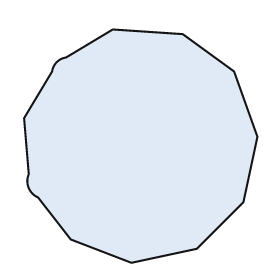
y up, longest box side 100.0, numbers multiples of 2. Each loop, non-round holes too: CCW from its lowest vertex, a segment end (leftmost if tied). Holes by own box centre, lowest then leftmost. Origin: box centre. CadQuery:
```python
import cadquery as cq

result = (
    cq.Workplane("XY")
    .moveTo(-4.0, -50.0)
    .lineTo(24.0, -44.0)
    .lineTo(44.0, -24.0)
    .lineTo(50.0, 4.0)
    .lineTo(40.0, 32.0)
    .lineTo(18.0, 48.0)
    .lineTo(-12.0, 50.0)
    .lineTo(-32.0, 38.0)
    .threePointArc((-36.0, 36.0), (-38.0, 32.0))
    .lineTo(-50.0, 12.0)
    .lineTo(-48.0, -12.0)
    .threePointArc((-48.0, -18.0), (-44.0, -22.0))
    .lineTo(-30.0, -40.0)
    .close()
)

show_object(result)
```